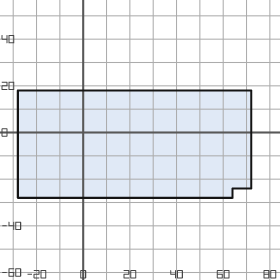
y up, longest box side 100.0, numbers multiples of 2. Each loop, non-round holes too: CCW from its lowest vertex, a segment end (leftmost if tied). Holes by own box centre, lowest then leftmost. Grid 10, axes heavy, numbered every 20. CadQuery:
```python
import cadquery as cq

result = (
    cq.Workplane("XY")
    .moveTo(-28.0, -28.0)
    .lineTo(64.0, -28.0)
    .lineTo(64.0, -24.0)
    .lineTo(72.0, -24.0)
    .lineTo(72.0, 18.0)
    .lineTo(-28.0, 18.0)
    .close()
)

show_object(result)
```